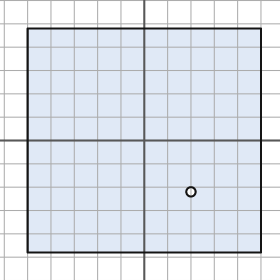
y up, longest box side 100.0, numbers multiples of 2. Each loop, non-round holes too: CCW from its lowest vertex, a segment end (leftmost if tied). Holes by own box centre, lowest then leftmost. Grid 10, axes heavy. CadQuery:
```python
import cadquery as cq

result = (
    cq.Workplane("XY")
    .moveTo(-50.0, -48.0)
    .lineTo(50.0, -48.0)
    .lineTo(50.0, 48.0)
    .lineTo(-50.0, 48.0)
    .close()
    .moveTo(20.0, -22.0)
    .circle(2.0)
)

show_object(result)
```